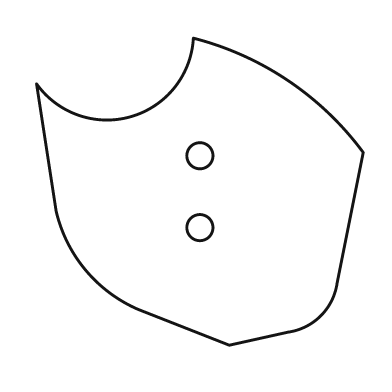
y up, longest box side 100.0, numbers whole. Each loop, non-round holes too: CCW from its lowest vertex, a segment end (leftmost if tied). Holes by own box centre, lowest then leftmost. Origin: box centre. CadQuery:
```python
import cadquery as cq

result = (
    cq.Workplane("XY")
    .moveTo(9.0, -47.0)
    .lineTo(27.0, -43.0)
    .threePointArc((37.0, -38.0), (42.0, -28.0))
    .lineTo(50.0, 12.0)
    .threePointArc((27.0, 34.0), (-2.0, 47.0))
    .threePointArc((-21.0, 23.0), (-50.0, 33.0))
    .lineTo(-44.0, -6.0)
    .threePointArc((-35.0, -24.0), (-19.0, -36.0))
    .close()
    .moveTo(0.0, -11.0)
    .circle(4.0)
    .moveTo(0.0, 11.0)
    .circle(4.0)
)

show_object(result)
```